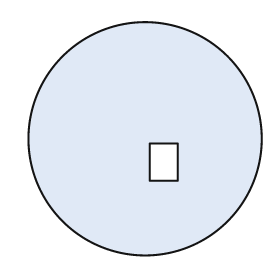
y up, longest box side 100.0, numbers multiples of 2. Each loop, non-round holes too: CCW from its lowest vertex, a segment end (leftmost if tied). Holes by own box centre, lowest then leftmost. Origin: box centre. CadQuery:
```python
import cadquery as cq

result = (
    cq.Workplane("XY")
    .moveTo(0.0, 0.0)
    .circle(50.0)
    .moveTo(2.0, -18.0)
    .lineTo(14.0, -18.0)
    .lineTo(14.0, -2.0)
    .lineTo(2.0, -2.0)
    .close()
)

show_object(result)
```